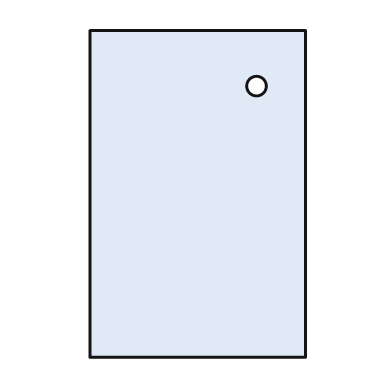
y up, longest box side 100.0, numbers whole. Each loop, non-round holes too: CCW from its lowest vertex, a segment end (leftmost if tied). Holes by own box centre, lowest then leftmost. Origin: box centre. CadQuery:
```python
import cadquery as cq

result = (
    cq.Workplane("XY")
    .moveTo(-33.0, -50.0)
    .lineTo(33.0, -50.0)
    .lineTo(33.0, 50.0)
    .lineTo(-33.0, 50.0)
    .close()
    .moveTo(18.0, 33.0)
    .circle(3.0)
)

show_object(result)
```